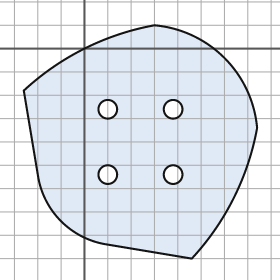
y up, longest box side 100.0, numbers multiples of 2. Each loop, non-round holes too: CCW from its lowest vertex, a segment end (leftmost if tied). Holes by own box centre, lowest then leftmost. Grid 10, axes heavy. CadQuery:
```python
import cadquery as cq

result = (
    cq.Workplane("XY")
    .moveTo(46.0, -90.0)
    .threePointArc((64.0, -64.0), (74.0, -34.0))
    .threePointArc((60.0, -4.0), (30.0, 10.0))
    .threePointArc((0.0, 0.0), (-26.0, -18.0))
    .lineTo(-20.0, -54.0)
    .threePointArc((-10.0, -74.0), (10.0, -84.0))
    .close()
    .moveTo(10.0, -54.0)
    .circle(4.0)
    .moveTo(38.0, -54.0)
    .circle(4.0)
    .moveTo(10.0, -26.0)
    .circle(4.0)
    .moveTo(38.0, -26.0)
    .circle(4.0)
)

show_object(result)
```